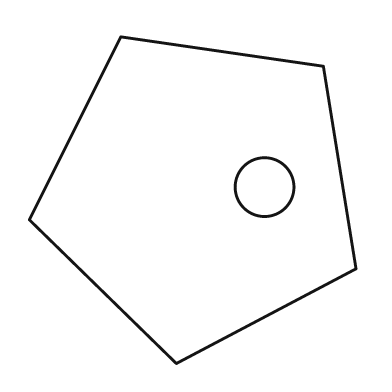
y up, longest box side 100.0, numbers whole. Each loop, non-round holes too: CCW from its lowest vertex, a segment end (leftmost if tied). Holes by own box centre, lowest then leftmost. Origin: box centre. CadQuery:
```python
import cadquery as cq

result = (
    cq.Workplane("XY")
    .moveTo(-5.0, -50.0)
    .lineTo(50.0, -21.0)
    .lineTo(40.0, 41.0)
    .lineTo(-22.0, 50.0)
    .lineTo(-50.0, -6.0)
    .close()
    .moveTo(22.0, 4.0)
    .circle(9.0)
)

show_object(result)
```